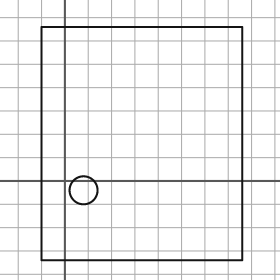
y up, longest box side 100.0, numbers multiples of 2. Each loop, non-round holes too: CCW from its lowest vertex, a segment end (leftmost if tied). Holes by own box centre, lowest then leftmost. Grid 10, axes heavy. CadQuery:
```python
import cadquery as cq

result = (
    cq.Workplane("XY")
    .moveTo(-10.0, -34.0)
    .lineTo(76.0, -34.0)
    .lineTo(76.0, 66.0)
    .lineTo(-10.0, 66.0)
    .close()
    .moveTo(8.0, -4.0)
    .circle(6.0)
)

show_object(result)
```